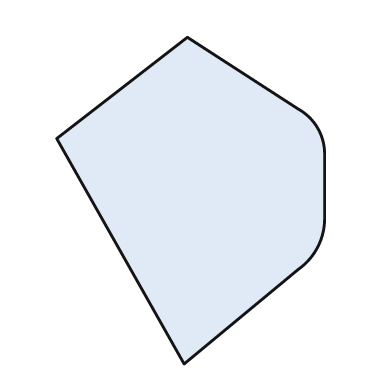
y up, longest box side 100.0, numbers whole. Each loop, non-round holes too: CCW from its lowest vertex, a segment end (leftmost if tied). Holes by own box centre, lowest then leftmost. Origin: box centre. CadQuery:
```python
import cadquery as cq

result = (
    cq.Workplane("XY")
    .moveTo(-2.0, -50.0)
    .lineTo(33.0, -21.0)
    .threePointArc((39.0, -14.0), (41.0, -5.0))
    .lineTo(41.0, 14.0)
    .threePointArc((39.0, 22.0), (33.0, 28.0))
    .lineTo(-1.0, 50.0)
    .lineTo(-41.0, 19.0)
    .close()
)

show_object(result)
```